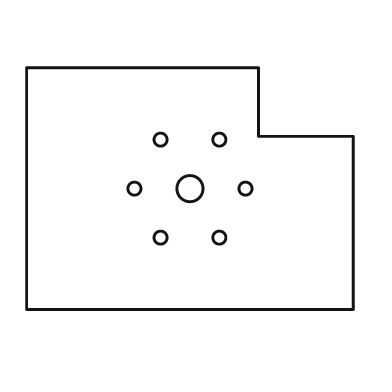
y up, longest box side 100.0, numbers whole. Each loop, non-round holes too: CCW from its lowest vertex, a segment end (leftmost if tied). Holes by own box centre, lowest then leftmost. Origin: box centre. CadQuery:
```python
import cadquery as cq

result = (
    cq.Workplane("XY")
    .moveTo(-50.0, -37.0)
    .lineTo(50.0, -37.0)
    .lineTo(50.0, 16.0)
    .lineTo(21.0, 16.0)
    .lineTo(21.0, 37.0)
    .lineTo(-50.0, 37.0)
    .close()
    .moveTo(-9.0, -15.0)
    .circle(2.0)
    .moveTo(9.0, -15.0)
    .circle(2.0)
    .moveTo(-17.0, 0.0)
    .circle(2.0)
    .moveTo(0.0, 0.0)
    .circle(4.0)
    .moveTo(17.0, 0.0)
    .circle(2.0)
    .moveTo(-9.0, 15.0)
    .circle(2.0)
    .moveTo(9.0, 15.0)
    .circle(2.0)
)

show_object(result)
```